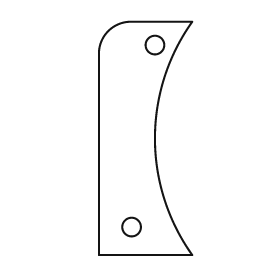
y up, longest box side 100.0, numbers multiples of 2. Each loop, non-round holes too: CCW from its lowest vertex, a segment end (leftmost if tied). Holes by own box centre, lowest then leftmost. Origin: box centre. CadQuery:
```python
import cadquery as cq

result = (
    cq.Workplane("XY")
    .moveTo(-20.0, -50.0)
    .lineTo(20.0, -50.0)
    .threePointArc((4.0, 0.0), (20.0, 50.0))
    .lineTo(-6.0, 50.0)
    .threePointArc((-16.0, 46.0), (-20.0, 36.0))
    .close()
    .moveTo(-6.0, -38.0)
    .circle(4.0)
    .moveTo(4.0, 40.0)
    .circle(4.0)
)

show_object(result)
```